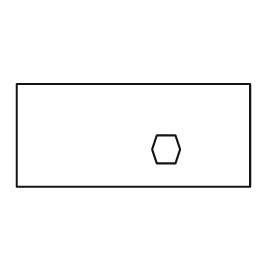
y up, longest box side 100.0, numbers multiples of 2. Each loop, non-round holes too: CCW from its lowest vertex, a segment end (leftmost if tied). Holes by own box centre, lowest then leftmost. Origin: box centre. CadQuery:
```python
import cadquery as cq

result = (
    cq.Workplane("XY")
    .moveTo(-50.0, -22.0)
    .lineTo(50.0, -22.0)
    .lineTo(50.0, 22.0)
    .lineTo(-50.0, 22.0)
    .close()
    .moveTo(10.0, -12.0)
    .lineTo(18.0, -12.0)
    .lineTo(20.0, -6.0)
    .lineTo(18.0, 0.0)
    .lineTo(10.0, 0.0)
    .lineTo(8.0, -6.0)
    .close()
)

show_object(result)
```